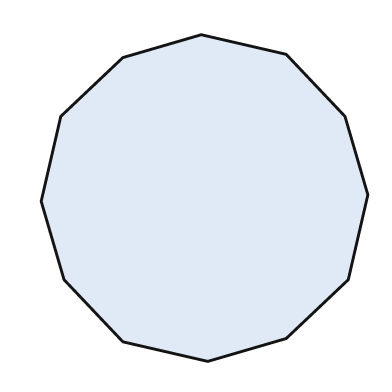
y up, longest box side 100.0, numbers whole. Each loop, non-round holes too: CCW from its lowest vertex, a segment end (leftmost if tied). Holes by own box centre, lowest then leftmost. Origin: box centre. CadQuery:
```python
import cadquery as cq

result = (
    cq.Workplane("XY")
    .moveTo(1.0, -50.0)
    .lineTo(25.0, -43.0)
    .lineTo(44.0, -25.0)
    .lineTo(50.0, 1.0)
    .lineTo(43.0, 25.0)
    .lineTo(25.0, 44.0)
    .lineTo(-1.0, 50.0)
    .lineTo(-25.0, 43.0)
    .lineTo(-44.0, 25.0)
    .lineTo(-50.0, -1.0)
    .lineTo(-43.0, -25.0)
    .lineTo(-25.0, -44.0)
    .close()
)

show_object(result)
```